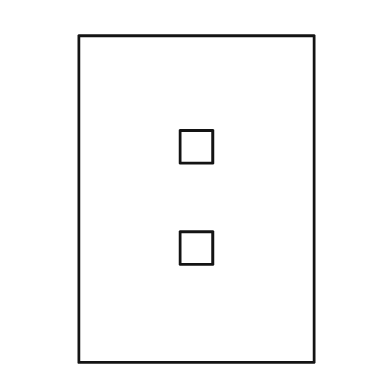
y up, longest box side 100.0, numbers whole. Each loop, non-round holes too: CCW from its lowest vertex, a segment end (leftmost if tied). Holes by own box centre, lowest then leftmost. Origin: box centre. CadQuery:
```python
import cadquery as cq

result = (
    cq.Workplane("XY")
    .moveTo(-36.0, -50.0)
    .lineTo(36.0, -50.0)
    .lineTo(36.0, 50.0)
    .lineTo(-36.0, 50.0)
    .close()
    .moveTo(-5.0, -20.0)
    .lineTo(5.0, -20.0)
    .lineTo(5.0, -10.0)
    .lineTo(-5.0, -10.0)
    .close()
    .moveTo(-5.0, 11.0)
    .lineTo(5.0, 11.0)
    .lineTo(5.0, 21.0)
    .lineTo(-5.0, 21.0)
    .close()
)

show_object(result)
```